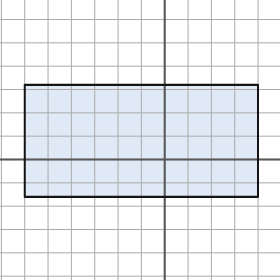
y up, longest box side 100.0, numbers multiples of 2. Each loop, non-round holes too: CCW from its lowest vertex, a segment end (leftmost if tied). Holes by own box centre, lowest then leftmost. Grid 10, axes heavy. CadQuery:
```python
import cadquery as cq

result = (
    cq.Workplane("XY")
    .moveTo(-60.0, -16.0)
    .lineTo(40.0, -16.0)
    .lineTo(40.0, 32.0)
    .lineTo(-60.0, 32.0)
    .close()
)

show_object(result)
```